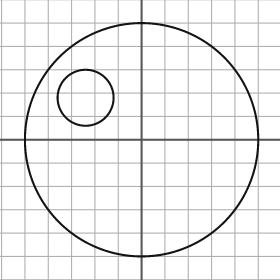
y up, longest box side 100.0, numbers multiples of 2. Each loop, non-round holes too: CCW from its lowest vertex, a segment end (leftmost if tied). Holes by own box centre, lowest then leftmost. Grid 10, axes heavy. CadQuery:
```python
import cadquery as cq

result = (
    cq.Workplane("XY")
    .moveTo(0.0, 0.0)
    .circle(50.0)
    .moveTo(-24.0, 18.0)
    .circle(12.0)
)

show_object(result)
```